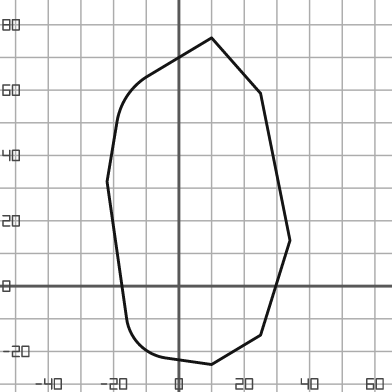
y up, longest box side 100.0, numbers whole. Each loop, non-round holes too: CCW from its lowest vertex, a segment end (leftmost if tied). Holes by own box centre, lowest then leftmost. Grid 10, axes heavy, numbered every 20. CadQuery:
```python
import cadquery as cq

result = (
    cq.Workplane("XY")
    .moveTo(10.0, -24.0)
    .lineTo(25.0, -15.0)
    .lineTo(34.0, 14.0)
    .lineTo(25.0, 59.0)
    .lineTo(10.0, 76.0)
    .lineTo(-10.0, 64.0)
    .threePointArc((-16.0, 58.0), (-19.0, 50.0))
    .lineTo(-22.0, 32.0)
    .lineTo(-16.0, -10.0)
    .threePointArc((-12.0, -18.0), (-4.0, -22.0))
    .close()
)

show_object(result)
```